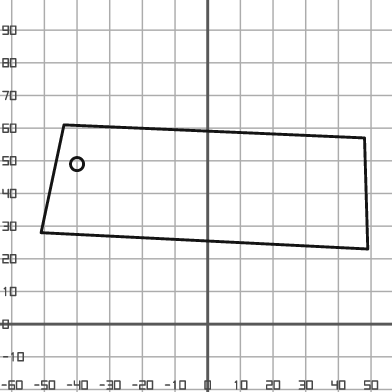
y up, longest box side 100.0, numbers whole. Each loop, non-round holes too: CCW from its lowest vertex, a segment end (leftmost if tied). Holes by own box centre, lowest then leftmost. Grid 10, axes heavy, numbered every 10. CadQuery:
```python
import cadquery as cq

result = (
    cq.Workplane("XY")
    .moveTo(49.0, 23.0)
    .lineTo(48.0, 57.0)
    .lineTo(-44.0, 61.0)
    .lineTo(-51.0, 28.0)
    .close()
    .moveTo(-40.0, 49.0)
    .circle(2.0)
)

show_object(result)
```